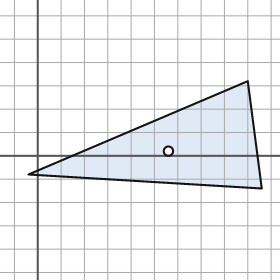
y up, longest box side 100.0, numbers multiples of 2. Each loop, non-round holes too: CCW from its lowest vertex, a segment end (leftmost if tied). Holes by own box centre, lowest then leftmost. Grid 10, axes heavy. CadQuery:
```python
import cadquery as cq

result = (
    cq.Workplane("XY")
    .moveTo(96.0, -14.0)
    .lineTo(90.0, 32.0)
    .lineTo(-4.0, -8.0)
    .close()
    .moveTo(56.0, 2.0)
    .circle(2.0)
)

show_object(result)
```